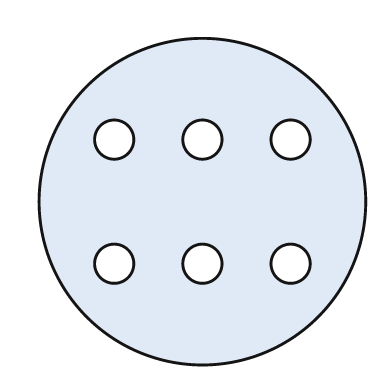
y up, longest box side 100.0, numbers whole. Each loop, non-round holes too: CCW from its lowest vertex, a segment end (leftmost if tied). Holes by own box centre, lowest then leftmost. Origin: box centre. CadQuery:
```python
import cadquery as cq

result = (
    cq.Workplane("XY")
    .moveTo(0.0, 0.0)
    .circle(50.0)
    .moveTo(-27.0, -19.0)
    .circle(6.0)
    .moveTo(0.0, -19.0)
    .circle(6.0)
    .moveTo(27.0, -19.0)
    .circle(6.0)
    .moveTo(-27.0, 19.0)
    .circle(6.0)
    .moveTo(0.0, 19.0)
    .circle(6.0)
    .moveTo(27.0, 19.0)
    .circle(6.0)
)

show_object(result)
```